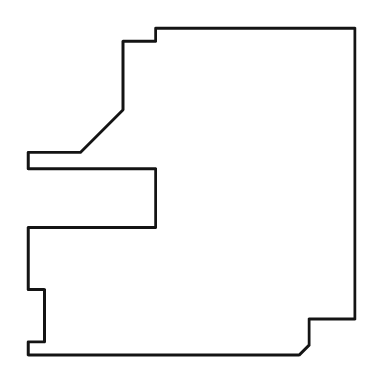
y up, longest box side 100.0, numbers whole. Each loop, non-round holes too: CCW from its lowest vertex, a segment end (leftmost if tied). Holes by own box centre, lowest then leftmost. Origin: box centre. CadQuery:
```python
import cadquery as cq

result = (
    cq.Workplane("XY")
    .moveTo(-50.0, -50.0)
    .lineTo(33.0, -50.0)
    .lineTo(36.0, -47.0)
    .lineTo(36.0, -39.0)
    .lineTo(50.0, -39.0)
    .lineTo(50.0, 50.0)
    .lineTo(-11.0, 50.0)
    .lineTo(-11.0, 46.0)
    .lineTo(-21.0, 46.0)
    .lineTo(-21.0, 25.0)
    .lineTo(-34.0, 12.0)
    .lineTo(-50.0, 12.0)
    .lineTo(-50.0, 7.0)
    .lineTo(-11.0, 7.0)
    .lineTo(-11.0, -11.0)
    .lineTo(-50.0, -11.0)
    .lineTo(-50.0, -30.0)
    .lineTo(-45.0, -30.0)
    .lineTo(-45.0, -46.0)
    .lineTo(-50.0, -46.0)
    .close()
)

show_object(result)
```